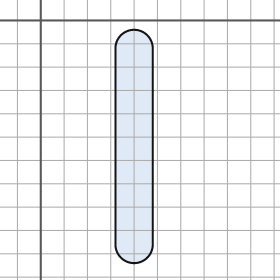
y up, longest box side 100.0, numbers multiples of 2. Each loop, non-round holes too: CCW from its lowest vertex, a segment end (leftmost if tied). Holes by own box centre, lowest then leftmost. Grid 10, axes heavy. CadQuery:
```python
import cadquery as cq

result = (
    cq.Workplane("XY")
    .moveTo(32.0, -96.0)
    .threePointArc((40.0, -104.0), (48.0, -96.0))
    .lineTo(48.0, -12.0)
    .threePointArc((40.0, -4.0), (32.0, -12.0))
    .close()
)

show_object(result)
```